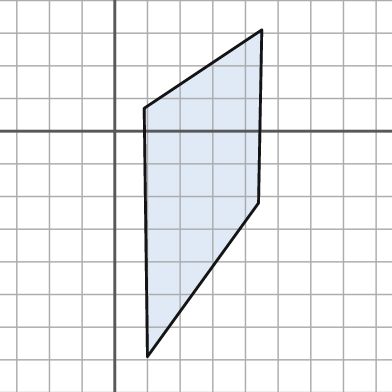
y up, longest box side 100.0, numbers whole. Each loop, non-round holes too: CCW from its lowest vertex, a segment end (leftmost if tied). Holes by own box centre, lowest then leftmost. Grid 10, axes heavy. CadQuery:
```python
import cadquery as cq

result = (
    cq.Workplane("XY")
    .moveTo(10.0, -69.0)
    .lineTo(44.0, -22.0)
    .lineTo(45.0, 31.0)
    .lineTo(9.0, 7.0)
    .close()
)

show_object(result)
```